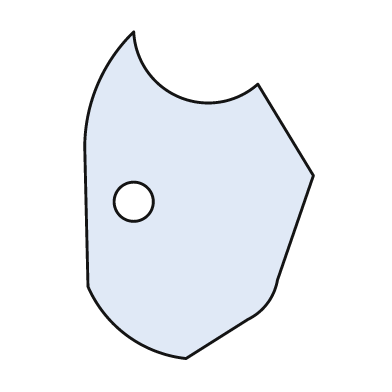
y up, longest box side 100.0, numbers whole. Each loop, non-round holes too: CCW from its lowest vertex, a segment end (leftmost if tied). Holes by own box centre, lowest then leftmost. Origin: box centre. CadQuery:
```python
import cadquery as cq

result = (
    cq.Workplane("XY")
    .moveTo(-4.0, -50.0)
    .lineTo(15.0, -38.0)
    .threePointArc((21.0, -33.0), (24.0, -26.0))
    .lineTo(35.0, 6.0)
    .lineTo(18.0, 34.0)
    .threePointArc((-6.0, 30.0), (-20.0, 50.0))
    .threePointArc((-31.0, 34.0), (-35.0, 15.0))
    .lineTo(-34.0, -28.0)
    .threePointArc((-22.0, -43.0), (-4.0, -50.0))
    .close()
    .moveTo(-20.0, -2.0)
    .circle(6.0)
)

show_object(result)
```